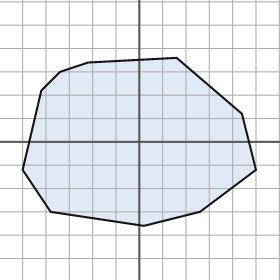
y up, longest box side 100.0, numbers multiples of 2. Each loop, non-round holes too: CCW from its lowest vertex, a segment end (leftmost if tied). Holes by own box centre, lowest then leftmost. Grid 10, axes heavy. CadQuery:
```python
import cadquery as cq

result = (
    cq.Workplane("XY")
    .moveTo(2.0, -36.0)
    .lineTo(26.0, -30.0)
    .lineTo(50.0, -12.0)
    .lineTo(44.0, 12.0)
    .lineTo(16.0, 36.0)
    .lineTo(-22.0, 34.0)
    .lineTo(-34.0, 30.0)
    .lineTo(-42.0, 22.0)
    .lineTo(-50.0, -12.0)
    .lineTo(-38.0, -30.0)
    .close()
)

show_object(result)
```